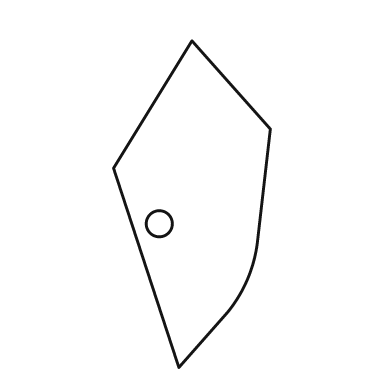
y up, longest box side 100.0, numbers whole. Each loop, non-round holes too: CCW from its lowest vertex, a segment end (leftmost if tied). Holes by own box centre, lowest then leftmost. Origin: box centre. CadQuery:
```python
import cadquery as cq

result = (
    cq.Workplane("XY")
    .moveTo(-4.0, -50.0)
    .lineTo(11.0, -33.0)
    .threePointArc((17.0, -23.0), (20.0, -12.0))
    .lineTo(24.0, 23.0)
    .lineTo(0.0, 50.0)
    .lineTo(-24.0, 11.0)
    .close()
    .moveTo(-10.0, -6.0)
    .circle(4.0)
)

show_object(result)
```